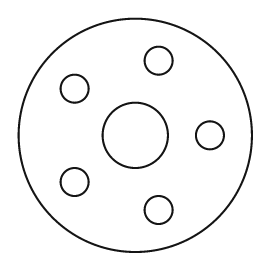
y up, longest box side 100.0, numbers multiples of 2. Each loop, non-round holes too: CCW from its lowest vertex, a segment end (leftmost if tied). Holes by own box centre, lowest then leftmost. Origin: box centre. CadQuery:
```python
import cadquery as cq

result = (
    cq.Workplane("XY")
    .moveTo(0.0, 0.0)
    .circle(50.0)
    .moveTo(10.0, -32.0)
    .circle(6.0)
    .moveTo(-26.0, -20.0)
    .circle(6.0)
    .moveTo(0.0, 0.0)
    .circle(14.0)
    .moveTo(32.0, 0.0)
    .circle(6.0)
    .moveTo(-26.0, 20.0)
    .circle(6.0)
    .moveTo(10.0, 32.0)
    .circle(6.0)
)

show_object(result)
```